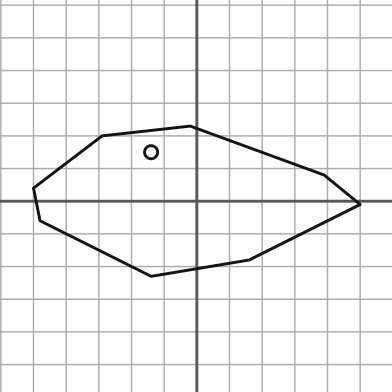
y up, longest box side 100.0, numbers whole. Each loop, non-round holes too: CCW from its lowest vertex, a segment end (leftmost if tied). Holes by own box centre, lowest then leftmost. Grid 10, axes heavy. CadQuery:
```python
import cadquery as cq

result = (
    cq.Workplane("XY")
    .moveTo(-14.0, -23.0)
    .lineTo(16.0, -18.0)
    .lineTo(50.0, -1.0)
    .lineTo(39.0, 8.0)
    .lineTo(-2.0, 23.0)
    .lineTo(-29.0, 20.0)
    .lineTo(-50.0, 4.0)
    .lineTo(-48.0, -6.0)
    .close()
    .moveTo(-14.0, 15.0)
    .circle(2.0)
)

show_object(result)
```